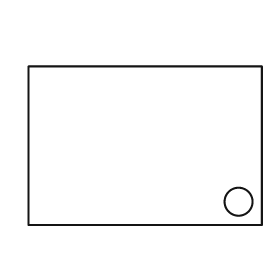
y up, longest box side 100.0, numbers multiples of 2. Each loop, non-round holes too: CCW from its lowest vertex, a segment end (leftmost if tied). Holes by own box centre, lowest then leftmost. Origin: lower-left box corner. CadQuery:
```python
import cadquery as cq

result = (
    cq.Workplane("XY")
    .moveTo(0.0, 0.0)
    .lineTo(100.0, 0.0)
    .lineTo(100.0, 68.0)
    .lineTo(0.0, 68.0)
    .close()
    .moveTo(90.0, 10.0)
    .circle(6.0)
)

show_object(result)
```